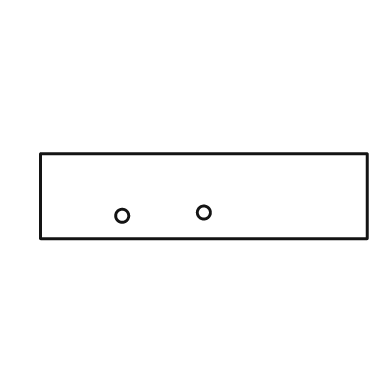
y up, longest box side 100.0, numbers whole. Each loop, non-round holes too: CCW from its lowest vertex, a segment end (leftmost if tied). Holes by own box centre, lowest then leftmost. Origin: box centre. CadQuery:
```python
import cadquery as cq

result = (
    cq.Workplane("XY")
    .moveTo(-50.0, -13.0)
    .lineTo(50.0, -13.0)
    .lineTo(50.0, 13.0)
    .lineTo(-50.0, 13.0)
    .close()
    .moveTo(-25.0, -6.0)
    .circle(2.0)
    .moveTo(0.0, -5.0)
    .circle(2.0)
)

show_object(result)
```